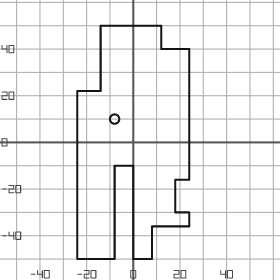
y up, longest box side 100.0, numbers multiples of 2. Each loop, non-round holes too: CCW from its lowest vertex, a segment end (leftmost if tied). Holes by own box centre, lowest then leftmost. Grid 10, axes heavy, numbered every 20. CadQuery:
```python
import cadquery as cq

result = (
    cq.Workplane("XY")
    .moveTo(-24.0, -50.0)
    .lineTo(-8.0, -50.0)
    .lineTo(-8.0, -10.0)
    .lineTo(0.0, -10.0)
    .lineTo(0.0, -50.0)
    .lineTo(8.0, -50.0)
    .lineTo(8.0, -36.0)
    .lineTo(24.0, -36.0)
    .lineTo(24.0, -30.0)
    .lineTo(18.0, -30.0)
    .lineTo(18.0, -16.0)
    .lineTo(24.0, -16.0)
    .lineTo(24.0, 40.0)
    .lineTo(12.0, 40.0)
    .lineTo(12.0, 50.0)
    .lineTo(-14.0, 50.0)
    .lineTo(-14.0, 22.0)
    .lineTo(-24.0, 22.0)
    .close()
    .moveTo(-8.0, 10.0)
    .circle(2.0)
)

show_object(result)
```